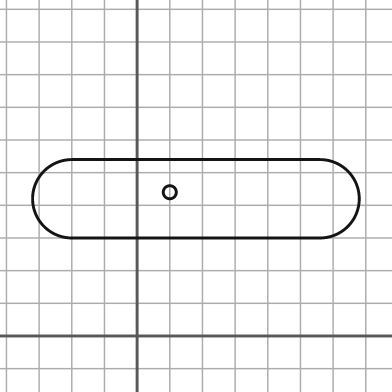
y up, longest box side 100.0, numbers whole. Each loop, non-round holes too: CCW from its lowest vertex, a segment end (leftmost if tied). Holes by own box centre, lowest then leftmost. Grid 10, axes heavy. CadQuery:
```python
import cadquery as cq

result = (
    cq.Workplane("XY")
    .moveTo(-20.0, 30.0)
    .lineTo(56.0, 30.0)
    .threePointArc((68.0, 42.0), (56.0, 54.0))
    .lineTo(-20.0, 54.0)
    .threePointArc((-32.0, 42.0), (-20.0, 30.0))
    .close()
    .moveTo(10.0, 44.0)
    .circle(2.0)
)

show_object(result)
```